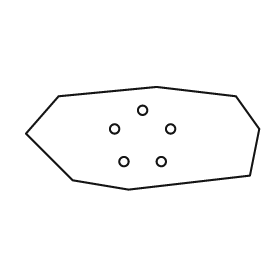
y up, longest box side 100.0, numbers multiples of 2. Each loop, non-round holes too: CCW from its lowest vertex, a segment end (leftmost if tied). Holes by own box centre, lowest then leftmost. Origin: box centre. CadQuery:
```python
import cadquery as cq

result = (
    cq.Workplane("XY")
    .moveTo(-6.0, -22.0)
    .lineTo(46.0, -16.0)
    .lineTo(50.0, 4.0)
    .lineTo(40.0, 18.0)
    .lineTo(6.0, 22.0)
    .lineTo(-36.0, 18.0)
    .lineTo(-50.0, 2.0)
    .lineTo(-30.0, -18.0)
    .close()
    .moveTo(-8.0, -10.0)
    .circle(2.0)
    .moveTo(8.0, -10.0)
    .circle(2.0)
    .moveTo(-12.0, 4.0)
    .circle(2.0)
    .moveTo(12.0, 4.0)
    .circle(2.0)
    .moveTo(0.0, 12.0)
    .circle(2.0)
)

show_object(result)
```